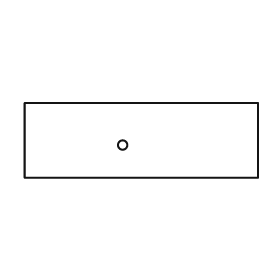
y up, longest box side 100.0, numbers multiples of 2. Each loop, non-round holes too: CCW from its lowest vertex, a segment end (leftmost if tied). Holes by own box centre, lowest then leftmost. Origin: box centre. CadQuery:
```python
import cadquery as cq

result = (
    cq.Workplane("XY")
    .moveTo(-50.0, -16.0)
    .lineTo(50.0, -16.0)
    .lineTo(50.0, 16.0)
    .lineTo(-50.0, 16.0)
    .close()
    .moveTo(-8.0, -2.0)
    .circle(2.0)
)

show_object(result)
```